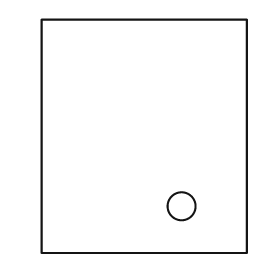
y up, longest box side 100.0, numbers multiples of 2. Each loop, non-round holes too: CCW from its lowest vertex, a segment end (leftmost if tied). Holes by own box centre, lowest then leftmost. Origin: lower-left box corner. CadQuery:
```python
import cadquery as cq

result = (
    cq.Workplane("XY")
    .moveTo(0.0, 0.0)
    .lineTo(88.0, 0.0)
    .lineTo(88.0, 100.0)
    .lineTo(0.0, 100.0)
    .close()
    .moveTo(60.0, 20.0)
    .circle(6.0)
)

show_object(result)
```